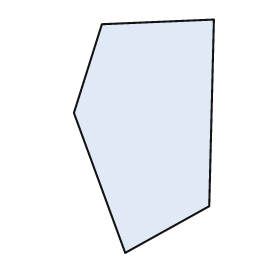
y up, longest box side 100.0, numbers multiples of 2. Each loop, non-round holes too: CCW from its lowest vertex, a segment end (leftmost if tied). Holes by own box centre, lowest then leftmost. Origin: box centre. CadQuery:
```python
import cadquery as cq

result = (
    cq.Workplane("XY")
    .moveTo(-8.0, -50.0)
    .lineTo(28.0, -30.0)
    .lineTo(30.0, 50.0)
    .lineTo(-18.0, 48.0)
    .lineTo(-30.0, 10.0)
    .close()
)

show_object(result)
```